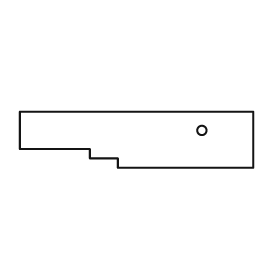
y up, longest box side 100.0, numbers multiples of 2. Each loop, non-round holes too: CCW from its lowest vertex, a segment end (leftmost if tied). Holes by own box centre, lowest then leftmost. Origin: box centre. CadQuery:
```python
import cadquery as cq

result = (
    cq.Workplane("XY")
    .moveTo(-8.0, -12.0)
    .lineTo(50.0, -12.0)
    .lineTo(50.0, 12.0)
    .lineTo(-50.0, 12.0)
    .lineTo(-50.0, -4.0)
    .lineTo(-20.0, -4.0)
    .lineTo(-20.0, -8.0)
    .lineTo(-8.0, -8.0)
    .close()
    .moveTo(28.0, 4.0)
    .circle(2.0)
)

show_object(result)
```